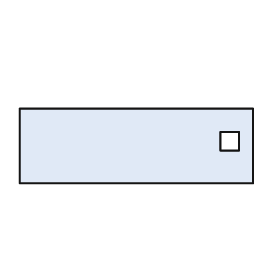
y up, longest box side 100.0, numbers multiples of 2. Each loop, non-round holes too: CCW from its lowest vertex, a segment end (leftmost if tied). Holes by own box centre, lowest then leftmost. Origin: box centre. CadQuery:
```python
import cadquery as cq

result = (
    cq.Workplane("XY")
    .moveTo(-50.0, -16.0)
    .lineTo(50.0, -16.0)
    .lineTo(50.0, 16.0)
    .lineTo(-50.0, 16.0)
    .close()
    .moveTo(36.0, -2.0)
    .lineTo(44.0, -2.0)
    .lineTo(44.0, 6.0)
    .lineTo(36.0, 6.0)
    .close()
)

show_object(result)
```